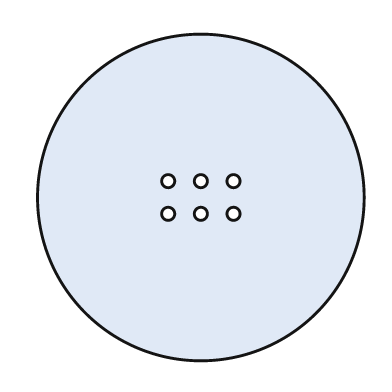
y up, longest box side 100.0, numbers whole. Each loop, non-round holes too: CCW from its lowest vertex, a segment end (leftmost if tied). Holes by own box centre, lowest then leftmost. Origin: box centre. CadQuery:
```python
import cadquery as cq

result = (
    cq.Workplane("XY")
    .moveTo(0.0, 0.0)
    .circle(50.0)
    .moveTo(-10.0, -5.0)
    .circle(2.0)
    .moveTo(0.0, -5.0)
    .circle(2.0)
    .moveTo(10.0, -5.0)
    .circle(2.0)
    .moveTo(-10.0, 5.0)
    .circle(2.0)
    .moveTo(0.0, 5.0)
    .circle(2.0)
    .moveTo(10.0, 5.0)
    .circle(2.0)
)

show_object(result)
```